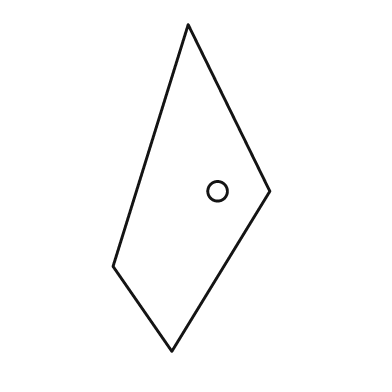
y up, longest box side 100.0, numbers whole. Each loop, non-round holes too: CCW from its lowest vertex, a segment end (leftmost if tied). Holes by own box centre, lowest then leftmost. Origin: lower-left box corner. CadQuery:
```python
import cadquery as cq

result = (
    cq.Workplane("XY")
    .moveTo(18.0, 0.0)
    .lineTo(48.0, 49.0)
    .lineTo(23.0, 100.0)
    .lineTo(0.0, 26.0)
    .close()
    .moveTo(32.0, 49.0)
    .circle(3.0)
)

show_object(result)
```